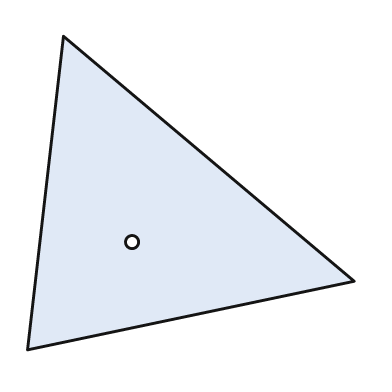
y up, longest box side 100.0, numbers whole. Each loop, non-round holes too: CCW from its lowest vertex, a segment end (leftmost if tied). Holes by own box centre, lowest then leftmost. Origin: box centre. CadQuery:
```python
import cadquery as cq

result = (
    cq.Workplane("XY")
    .moveTo(-50.0, -48.0)
    .lineTo(50.0, -27.0)
    .lineTo(-39.0, 48.0)
    .close()
    .moveTo(-18.0, -15.0)
    .circle(2.0)
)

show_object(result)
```